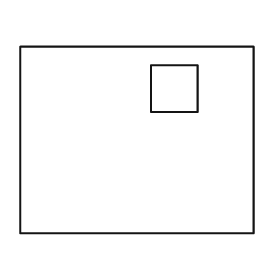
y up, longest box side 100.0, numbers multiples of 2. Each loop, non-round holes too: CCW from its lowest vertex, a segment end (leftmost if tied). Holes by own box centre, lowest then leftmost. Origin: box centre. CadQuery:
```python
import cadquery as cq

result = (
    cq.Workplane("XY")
    .moveTo(-50.0, -40.0)
    .lineTo(50.0, -40.0)
    .lineTo(50.0, 40.0)
    .lineTo(-50.0, 40.0)
    .close()
    .moveTo(6.0, 12.0)
    .lineTo(26.0, 12.0)
    .lineTo(26.0, 32.0)
    .lineTo(6.0, 32.0)
    .close()
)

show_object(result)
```